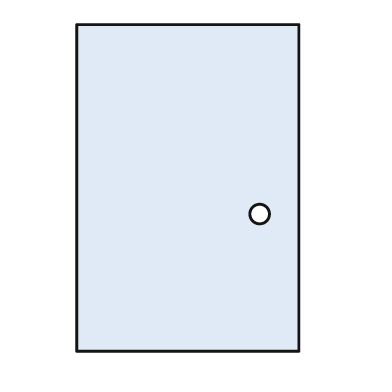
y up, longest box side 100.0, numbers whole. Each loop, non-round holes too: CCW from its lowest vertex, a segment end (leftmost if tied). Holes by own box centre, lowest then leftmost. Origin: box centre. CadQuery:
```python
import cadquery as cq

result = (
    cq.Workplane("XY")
    .moveTo(-34.0, -50.0)
    .lineTo(34.0, -50.0)
    .lineTo(34.0, 50.0)
    .lineTo(-34.0, 50.0)
    .close()
    .moveTo(22.0, -8.0)
    .circle(3.0)
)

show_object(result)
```